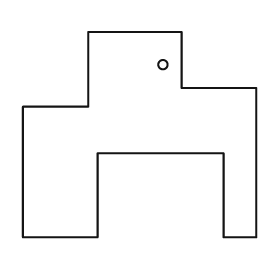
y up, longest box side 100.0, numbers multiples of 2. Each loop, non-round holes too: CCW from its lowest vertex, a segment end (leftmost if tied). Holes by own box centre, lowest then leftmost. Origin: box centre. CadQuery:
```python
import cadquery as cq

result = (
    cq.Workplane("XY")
    .moveTo(-50.0, -44.0)
    .lineTo(-18.0, -44.0)
    .lineTo(-18.0, -8.0)
    .lineTo(36.0, -8.0)
    .lineTo(36.0, -44.0)
    .lineTo(50.0, -44.0)
    .lineTo(50.0, 20.0)
    .lineTo(18.0, 20.0)
    .lineTo(18.0, 44.0)
    .lineTo(-22.0, 44.0)
    .lineTo(-22.0, 12.0)
    .lineTo(-50.0, 12.0)
    .close()
    .moveTo(10.0, 30.0)
    .circle(2.0)
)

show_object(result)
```